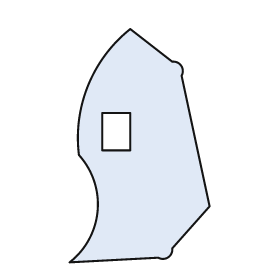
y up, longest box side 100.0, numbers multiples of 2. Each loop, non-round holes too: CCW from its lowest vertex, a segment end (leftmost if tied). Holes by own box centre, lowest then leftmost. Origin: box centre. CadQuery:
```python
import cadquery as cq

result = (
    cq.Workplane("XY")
    .moveTo(-30.0, -50.0)
    .lineTo(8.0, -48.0)
    .threePointArc((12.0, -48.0), (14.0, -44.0))
    .lineTo(30.0, -26.0)
    .lineTo(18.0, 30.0)
    .threePointArc((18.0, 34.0), (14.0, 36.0))
    .lineTo(-4.0, 50.0)
    .threePointArc((-22.0, 26.0), (-26.0, -4.0))
    .threePointArc((-18.0, -28.0), (-30.0, -50.0))
    .close()
    .moveTo(-16.0, -2.0)
    .lineTo(-4.0, -2.0)
    .lineTo(-4.0, 14.0)
    .lineTo(-16.0, 14.0)
    .close()
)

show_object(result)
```